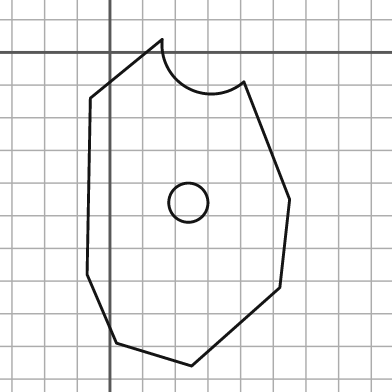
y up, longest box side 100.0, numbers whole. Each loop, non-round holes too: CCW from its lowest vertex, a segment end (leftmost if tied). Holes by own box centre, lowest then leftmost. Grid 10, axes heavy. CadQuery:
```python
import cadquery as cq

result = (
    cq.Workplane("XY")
    .moveTo(25.0, -96.0)
    .lineTo(52.0, -72.0)
    .lineTo(55.0, -45.0)
    .lineTo(41.0, -9.0)
    .threePointArc((24.0, -11.0), (16.0, 4.0))
    .lineTo(-6.0, -14.0)
    .lineTo(-7.0, -68.0)
    .lineTo(2.0, -89.0)
    .close()
    .moveTo(24.0, -46.0)
    .circle(6.0)
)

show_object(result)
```